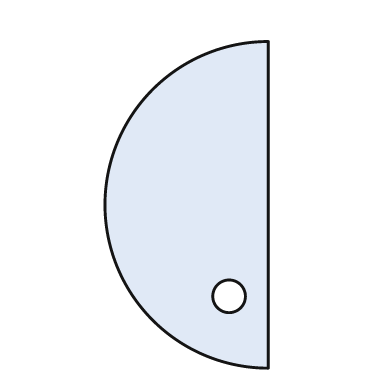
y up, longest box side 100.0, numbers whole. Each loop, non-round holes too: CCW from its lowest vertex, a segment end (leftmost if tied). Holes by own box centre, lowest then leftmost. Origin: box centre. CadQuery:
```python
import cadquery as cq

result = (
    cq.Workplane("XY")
    .moveTo(25.0, -50.0)
    .lineTo(25.0, 50.0)
    .threePointArc((-25.0, 0.0), (25.0, -50.0))
    .close()
    .moveTo(13.0, -28.0)
    .circle(5.0)
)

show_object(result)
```